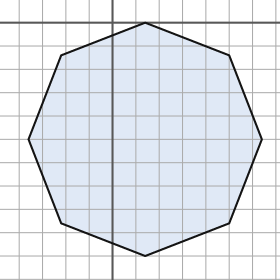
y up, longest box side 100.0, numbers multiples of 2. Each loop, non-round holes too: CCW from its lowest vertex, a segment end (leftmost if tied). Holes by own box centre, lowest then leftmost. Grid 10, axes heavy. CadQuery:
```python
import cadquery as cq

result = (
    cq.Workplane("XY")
    .moveTo(14.0, -100.0)
    .lineTo(50.0, -86.0)
    .lineTo(64.0, -50.0)
    .lineTo(50.0, -14.0)
    .lineTo(14.0, 0.0)
    .lineTo(-22.0, -14.0)
    .lineTo(-36.0, -50.0)
    .lineTo(-22.0, -86.0)
    .close()
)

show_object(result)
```